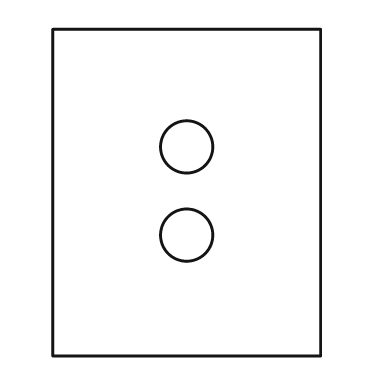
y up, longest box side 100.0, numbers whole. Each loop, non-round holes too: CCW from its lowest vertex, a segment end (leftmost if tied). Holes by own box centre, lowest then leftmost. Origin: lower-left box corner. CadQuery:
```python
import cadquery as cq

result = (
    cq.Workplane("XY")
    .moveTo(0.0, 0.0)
    .lineTo(82.0, 0.0)
    .lineTo(82.0, 100.0)
    .lineTo(0.0, 100.0)
    .close()
    .moveTo(41.0, 37.0)
    .circle(8.0)
    .moveTo(41.0, 64.0)
    .circle(8.0)
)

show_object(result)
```